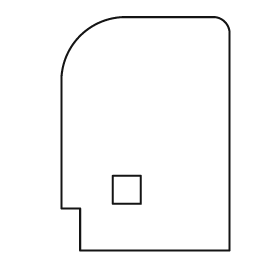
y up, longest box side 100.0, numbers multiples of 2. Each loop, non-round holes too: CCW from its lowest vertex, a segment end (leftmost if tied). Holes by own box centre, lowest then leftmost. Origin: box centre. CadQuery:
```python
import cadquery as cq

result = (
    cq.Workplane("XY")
    .moveTo(-28.0, -50.0)
    .lineTo(36.0, -50.0)
    .lineTo(36.0, 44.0)
    .threePointArc((34.0, 48.0), (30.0, 50.0))
    .lineTo(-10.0, 50.0)
    .threePointArc((-28.0, 42.0), (-36.0, 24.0))
    .lineTo(-36.0, -32.0)
    .lineTo(-28.0, -32.0)
    .close()
    .moveTo(-14.0, -30.0)
    .lineTo(-2.0, -30.0)
    .lineTo(-2.0, -18.0)
    .lineTo(-14.0, -18.0)
    .close()
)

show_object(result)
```